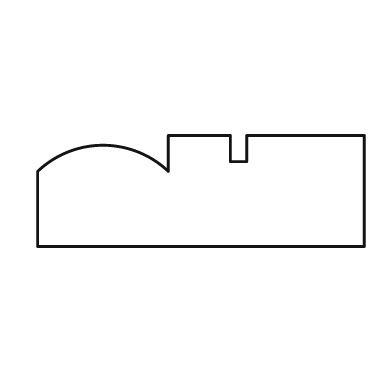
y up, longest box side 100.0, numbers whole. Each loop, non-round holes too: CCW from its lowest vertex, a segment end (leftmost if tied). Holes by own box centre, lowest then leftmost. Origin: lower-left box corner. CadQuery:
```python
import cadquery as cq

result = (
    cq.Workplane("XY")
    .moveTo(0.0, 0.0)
    .lineTo(100.0, 0.0)
    .lineTo(100.0, 34.0)
    .lineTo(64.0, 34.0)
    .lineTo(64.0, 26.0)
    .lineTo(59.0, 26.0)
    .lineTo(59.0, 34.0)
    .lineTo(40.0, 34.0)
    .lineTo(40.0, 23.0)
    .threePointArc((20.0, 31.0), (0.0, 23.0))
    .close()
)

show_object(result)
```